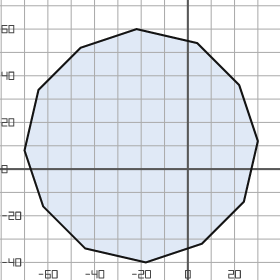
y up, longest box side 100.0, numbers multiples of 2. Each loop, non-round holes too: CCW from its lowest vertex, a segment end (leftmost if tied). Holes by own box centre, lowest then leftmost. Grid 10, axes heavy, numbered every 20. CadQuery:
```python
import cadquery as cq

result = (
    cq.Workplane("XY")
    .moveTo(-18.0, -40.0)
    .lineTo(6.0, -32.0)
    .lineTo(24.0, -14.0)
    .lineTo(30.0, 12.0)
    .lineTo(22.0, 36.0)
    .lineTo(4.0, 54.0)
    .lineTo(-22.0, 60.0)
    .lineTo(-46.0, 52.0)
    .lineTo(-64.0, 34.0)
    .lineTo(-70.0, 8.0)
    .lineTo(-62.0, -16.0)
    .lineTo(-44.0, -34.0)
    .close()
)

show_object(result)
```